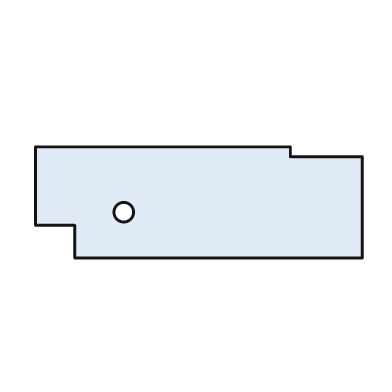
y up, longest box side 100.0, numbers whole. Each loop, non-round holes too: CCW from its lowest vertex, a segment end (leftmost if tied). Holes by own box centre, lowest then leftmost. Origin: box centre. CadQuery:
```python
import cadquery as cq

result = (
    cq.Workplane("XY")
    .moveTo(-38.0, -17.0)
    .lineTo(50.0, -17.0)
    .lineTo(50.0, 14.0)
    .lineTo(28.0, 14.0)
    .lineTo(28.0, 17.0)
    .lineTo(-50.0, 17.0)
    .lineTo(-50.0, -7.0)
    .lineTo(-38.0, -7.0)
    .close()
    .moveTo(-23.0, -3.0)
    .circle(3.0)
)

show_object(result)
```